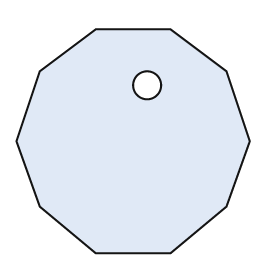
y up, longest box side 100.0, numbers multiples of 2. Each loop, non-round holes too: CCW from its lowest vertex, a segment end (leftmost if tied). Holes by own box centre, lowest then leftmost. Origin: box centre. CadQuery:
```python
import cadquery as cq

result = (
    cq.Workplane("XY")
    .moveTo(-16.0, -48.0)
    .lineTo(16.0, -48.0)
    .lineTo(40.0, -28.0)
    .lineTo(50.0, 0.0)
    .lineTo(40.0, 30.0)
    .lineTo(16.0, 48.0)
    .lineTo(-16.0, 48.0)
    .lineTo(-40.0, 30.0)
    .lineTo(-50.0, 0.0)
    .lineTo(-40.0, -28.0)
    .close()
    .moveTo(6.0, 24.0)
    .circle(6.0)
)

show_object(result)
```